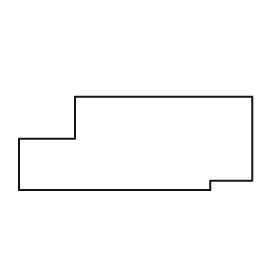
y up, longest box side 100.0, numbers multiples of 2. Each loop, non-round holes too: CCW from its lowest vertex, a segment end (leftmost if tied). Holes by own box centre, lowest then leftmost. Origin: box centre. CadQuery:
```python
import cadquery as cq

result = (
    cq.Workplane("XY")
    .moveTo(-50.0, -20.0)
    .lineTo(32.0, -20.0)
    .lineTo(32.0, -16.0)
    .lineTo(50.0, -16.0)
    .lineTo(50.0, 20.0)
    .lineTo(-26.0, 20.0)
    .lineTo(-26.0, 2.0)
    .lineTo(-50.0, 2.0)
    .close()
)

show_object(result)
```